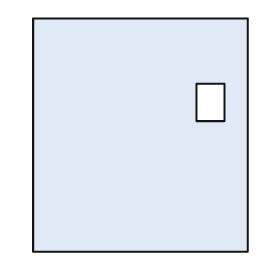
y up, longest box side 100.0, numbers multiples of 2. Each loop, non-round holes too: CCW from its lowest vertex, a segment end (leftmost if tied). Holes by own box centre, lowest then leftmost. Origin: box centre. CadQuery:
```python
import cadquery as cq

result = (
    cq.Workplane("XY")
    .moveTo(-46.0, -50.0)
    .lineTo(46.0, -50.0)
    .lineTo(46.0, 50.0)
    .lineTo(-46.0, 50.0)
    .close()
    .moveTo(24.0, 6.0)
    .lineTo(36.0, 6.0)
    .lineTo(36.0, 22.0)
    .lineTo(24.0, 22.0)
    .close()
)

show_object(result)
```